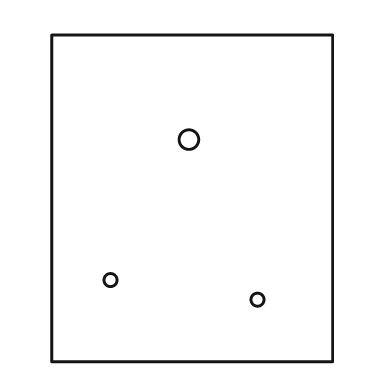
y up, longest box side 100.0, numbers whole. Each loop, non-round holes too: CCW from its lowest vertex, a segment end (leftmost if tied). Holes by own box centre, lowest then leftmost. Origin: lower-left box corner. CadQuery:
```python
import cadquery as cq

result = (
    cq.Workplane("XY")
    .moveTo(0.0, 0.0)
    .lineTo(86.0, 0.0)
    .lineTo(86.0, 100.0)
    .lineTo(0.0, 100.0)
    .close()
    .moveTo(63.0, 19.0)
    .circle(2.0)
    .moveTo(18.0, 25.0)
    .circle(2.0)
    .moveTo(42.0, 68.0)
    .circle(3.0)
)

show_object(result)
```